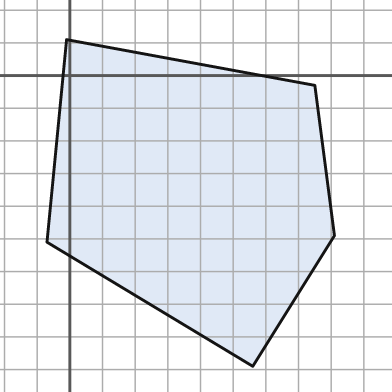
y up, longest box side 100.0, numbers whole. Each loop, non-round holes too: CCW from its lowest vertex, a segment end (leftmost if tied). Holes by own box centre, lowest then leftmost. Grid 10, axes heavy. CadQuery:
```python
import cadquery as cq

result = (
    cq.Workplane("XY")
    .moveTo(56.0, -89.0)
    .lineTo(81.0, -49.0)
    .lineTo(75.0, -3.0)
    .lineTo(-1.0, 11.0)
    .lineTo(-7.0, -51.0)
    .close()
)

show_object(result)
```